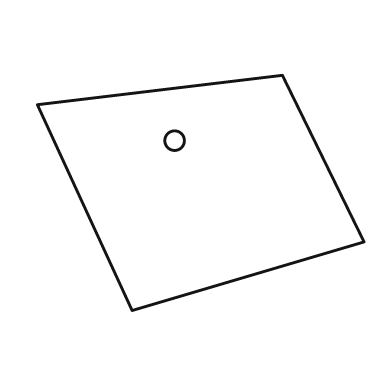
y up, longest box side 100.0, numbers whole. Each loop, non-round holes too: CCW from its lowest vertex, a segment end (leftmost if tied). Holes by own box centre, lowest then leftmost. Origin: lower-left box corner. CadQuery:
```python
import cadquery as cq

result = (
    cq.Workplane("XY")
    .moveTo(29.0, 0.0)
    .lineTo(100.0, 21.0)
    .lineTo(75.0, 72.0)
    .lineTo(0.0, 63.0)
    .close()
    .moveTo(42.0, 52.0)
    .circle(3.0)
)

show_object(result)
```